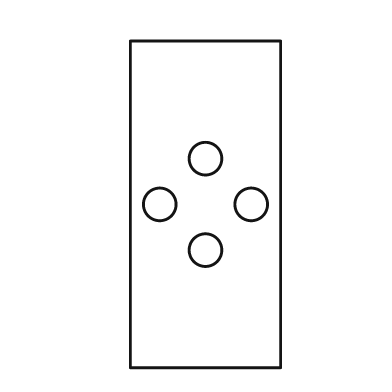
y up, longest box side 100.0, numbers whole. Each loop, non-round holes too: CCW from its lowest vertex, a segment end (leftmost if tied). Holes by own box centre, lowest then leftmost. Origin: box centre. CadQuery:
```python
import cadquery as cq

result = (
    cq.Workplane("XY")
    .moveTo(-23.0, -50.0)
    .lineTo(23.0, -50.0)
    .lineTo(23.0, 50.0)
    .lineTo(-23.0, 50.0)
    .close()
    .moveTo(0.0, -14.0)
    .circle(5.0)
    .moveTo(-14.0, 0.0)
    .circle(5.0)
    .moveTo(14.0, 0.0)
    .circle(5.0)
    .moveTo(0.0, 14.0)
    .circle(5.0)
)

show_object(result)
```